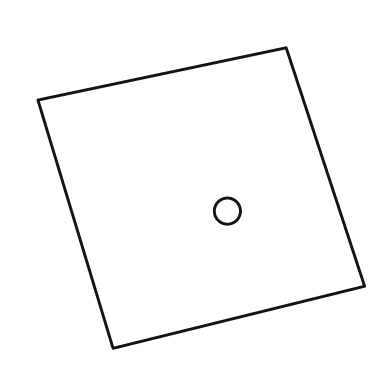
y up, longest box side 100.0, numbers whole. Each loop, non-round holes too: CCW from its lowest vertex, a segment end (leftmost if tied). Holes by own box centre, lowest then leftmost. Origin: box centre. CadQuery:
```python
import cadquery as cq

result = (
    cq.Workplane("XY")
    .moveTo(-27.0, -46.0)
    .lineTo(50.0, -27.0)
    .lineTo(26.0, 46.0)
    .lineTo(-50.0, 30.0)
    .close()
    .moveTo(8.0, -4.0)
    .circle(4.0)
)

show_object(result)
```